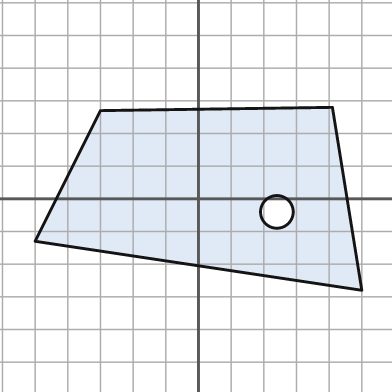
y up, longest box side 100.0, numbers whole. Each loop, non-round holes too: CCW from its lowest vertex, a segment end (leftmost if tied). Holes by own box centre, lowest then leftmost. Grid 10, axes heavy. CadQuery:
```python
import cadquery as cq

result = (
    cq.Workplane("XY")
    .moveTo(50.0, -28.0)
    .lineTo(41.0, 28.0)
    .lineTo(-30.0, 27.0)
    .lineTo(-50.0, -13.0)
    .close()
    .moveTo(24.0, -4.0)
    .circle(5.0)
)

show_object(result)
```